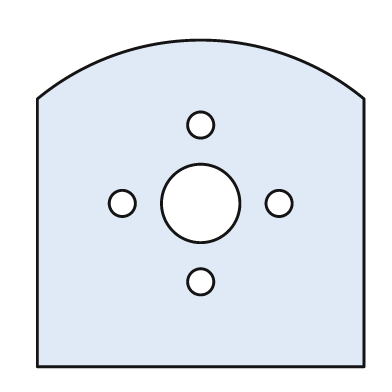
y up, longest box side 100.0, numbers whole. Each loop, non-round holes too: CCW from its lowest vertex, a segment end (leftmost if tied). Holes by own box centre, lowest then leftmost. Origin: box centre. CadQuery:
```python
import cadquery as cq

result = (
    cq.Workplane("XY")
    .moveTo(-50.0, -50.0)
    .lineTo(50.0, -50.0)
    .lineTo(50.0, 32.0)
    .threePointArc((0.0, 50.0), (-50.0, 32.0))
    .close()
    .moveTo(0.0, -24.0)
    .circle(4.0)
    .moveTo(-24.0, 0.0)
    .circle(4.0)
    .moveTo(0.0, 0.0)
    .circle(12.0)
    .moveTo(24.0, 0.0)
    .circle(4.0)
    .moveTo(0.0, 24.0)
    .circle(4.0)
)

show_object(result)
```